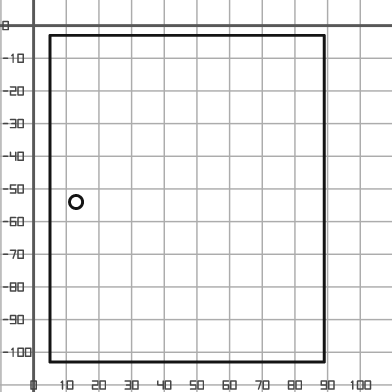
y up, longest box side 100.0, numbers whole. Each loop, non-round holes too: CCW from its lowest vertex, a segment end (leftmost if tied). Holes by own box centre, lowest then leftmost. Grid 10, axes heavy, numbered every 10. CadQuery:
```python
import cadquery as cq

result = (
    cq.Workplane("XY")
    .moveTo(5.0, -103.0)
    .lineTo(89.0, -103.0)
    .lineTo(89.0, -3.0)
    .lineTo(5.0, -3.0)
    .close()
    .moveTo(13.0, -54.0)
    .circle(2.0)
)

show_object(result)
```